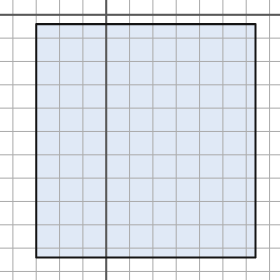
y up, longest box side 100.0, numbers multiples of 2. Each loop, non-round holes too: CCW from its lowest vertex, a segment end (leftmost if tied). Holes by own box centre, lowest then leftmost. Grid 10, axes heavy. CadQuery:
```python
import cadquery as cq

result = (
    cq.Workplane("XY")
    .moveTo(-30.0, -104.0)
    .lineTo(64.0, -104.0)
    .lineTo(64.0, -4.0)
    .lineTo(-30.0, -4.0)
    .close()
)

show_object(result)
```